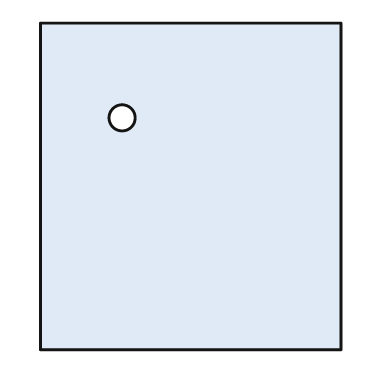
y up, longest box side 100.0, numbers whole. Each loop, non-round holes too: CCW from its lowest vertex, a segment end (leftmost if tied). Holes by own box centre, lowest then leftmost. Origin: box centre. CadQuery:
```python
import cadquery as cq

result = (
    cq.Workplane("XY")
    .moveTo(-46.0, -50.0)
    .lineTo(46.0, -50.0)
    .lineTo(46.0, 50.0)
    .lineTo(-46.0, 50.0)
    .close()
    .moveTo(-21.0, 21.0)
    .circle(4.0)
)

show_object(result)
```